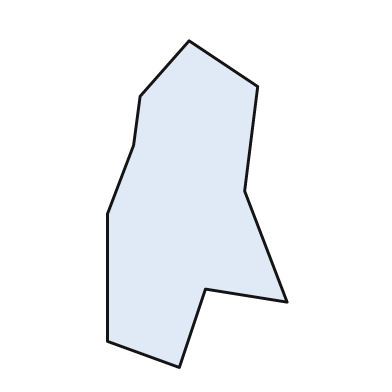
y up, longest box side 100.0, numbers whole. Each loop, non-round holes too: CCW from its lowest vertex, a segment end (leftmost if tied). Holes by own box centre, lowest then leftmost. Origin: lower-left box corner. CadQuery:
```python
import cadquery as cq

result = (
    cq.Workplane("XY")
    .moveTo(22.0, 0.0)
    .lineTo(30.0, 24.0)
    .lineTo(55.0, 20.0)
    .lineTo(42.0, 54.0)
    .lineTo(46.0, 86.0)
    .lineTo(25.0, 100.0)
    .lineTo(10.0, 83.0)
    .lineTo(8.0, 68.0)
    .lineTo(0.0, 47.0)
    .lineTo(0.0, 8.0)
    .close()
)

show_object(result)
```